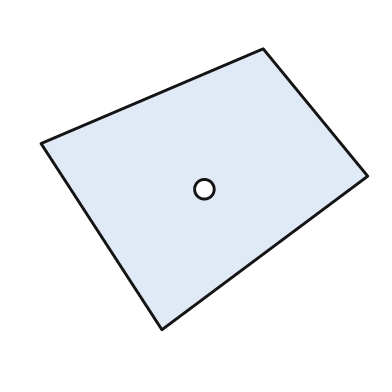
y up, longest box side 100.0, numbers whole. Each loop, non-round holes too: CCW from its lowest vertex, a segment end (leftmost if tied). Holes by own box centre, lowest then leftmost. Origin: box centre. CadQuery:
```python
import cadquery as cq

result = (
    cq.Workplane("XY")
    .moveTo(-13.0, -43.0)
    .lineTo(50.0, 4.0)
    .lineTo(18.0, 43.0)
    .lineTo(-50.0, 14.0)
    .close()
    .moveTo(0.0, 0.0)
    .circle(3.0)
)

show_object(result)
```